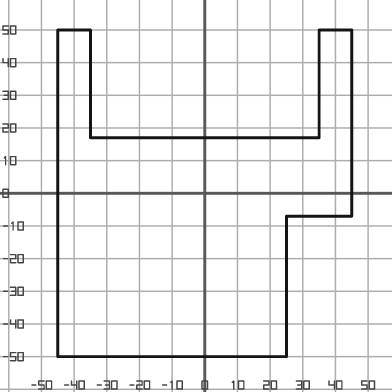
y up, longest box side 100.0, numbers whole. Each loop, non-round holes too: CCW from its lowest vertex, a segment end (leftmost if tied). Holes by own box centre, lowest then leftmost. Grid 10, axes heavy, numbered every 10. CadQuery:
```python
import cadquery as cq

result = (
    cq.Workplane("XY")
    .moveTo(-45.0, -50.0)
    .lineTo(25.0, -50.0)
    .lineTo(25.0, -7.0)
    .lineTo(45.0, -7.0)
    .lineTo(45.0, 50.0)
    .lineTo(35.0, 50.0)
    .lineTo(35.0, 17.0)
    .lineTo(-35.0, 17.0)
    .lineTo(-35.0, 50.0)
    .lineTo(-45.0, 50.0)
    .close()
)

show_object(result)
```